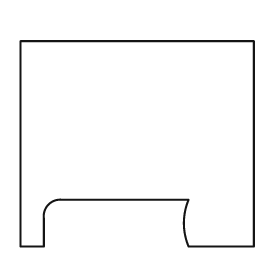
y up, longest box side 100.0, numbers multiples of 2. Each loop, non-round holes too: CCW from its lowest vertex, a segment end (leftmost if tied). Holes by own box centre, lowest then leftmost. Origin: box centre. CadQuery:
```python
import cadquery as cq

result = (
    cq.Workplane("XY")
    .moveTo(-50.0, -44.0)
    .lineTo(-40.0, -44.0)
    .lineTo(-40.0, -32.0)
    .threePointArc((-38.0, -26.0), (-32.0, -24.0))
    .lineTo(22.0, -24.0)
    .threePointArc((20.0, -34.0), (22.0, -44.0))
    .lineTo(50.0, -44.0)
    .lineTo(50.0, 44.0)
    .lineTo(-50.0, 44.0)
    .close()
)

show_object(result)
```